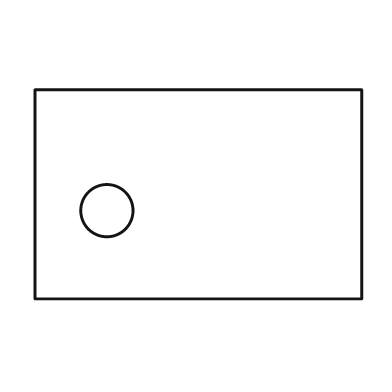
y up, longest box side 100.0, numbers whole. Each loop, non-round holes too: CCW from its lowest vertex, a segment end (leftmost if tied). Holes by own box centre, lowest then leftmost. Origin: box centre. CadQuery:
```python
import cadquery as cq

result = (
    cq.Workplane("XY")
    .moveTo(-50.0, -32.0)
    .lineTo(50.0, -32.0)
    .lineTo(50.0, 32.0)
    .lineTo(-50.0, 32.0)
    .close()
    .moveTo(-28.0, -5.0)
    .circle(8.0)
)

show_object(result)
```